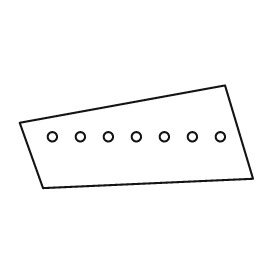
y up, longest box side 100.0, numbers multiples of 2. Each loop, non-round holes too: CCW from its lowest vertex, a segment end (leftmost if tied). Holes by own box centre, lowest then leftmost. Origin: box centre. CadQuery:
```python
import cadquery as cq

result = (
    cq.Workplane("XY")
    .moveTo(-40.0, -22.0)
    .lineTo(50.0, -18.0)
    .lineTo(38.0, 22.0)
    .lineTo(-50.0, 6.0)
    .close()
    .moveTo(-36.0, 0.0)
    .circle(2.0)
    .moveTo(-24.0, 0.0)
    .circle(2.0)
    .moveTo(-12.0, 0.0)
    .circle(2.0)
    .moveTo(0.0, 0.0)
    .circle(2.0)
    .moveTo(12.0, 0.0)
    .circle(2.0)
    .moveTo(24.0, 0.0)
    .circle(2.0)
    .moveTo(36.0, 0.0)
    .circle(2.0)
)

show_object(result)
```